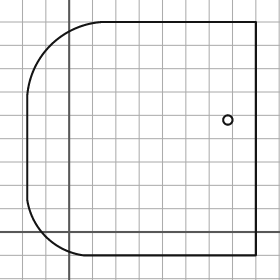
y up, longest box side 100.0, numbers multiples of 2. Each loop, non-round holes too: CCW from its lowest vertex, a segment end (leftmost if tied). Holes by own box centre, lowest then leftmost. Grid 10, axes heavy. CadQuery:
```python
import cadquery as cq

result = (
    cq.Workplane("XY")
    .moveTo(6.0, -10.0)
    .lineTo(80.0, -10.0)
    .lineTo(80.0, 90.0)
    .lineTo(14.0, 90.0)
    .threePointArc((-8.0, 80.0), (-18.0, 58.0))
    .lineTo(-18.0, 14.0)
    .threePointArc((-10.0, -2.0), (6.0, -10.0))
    .close()
    .moveTo(68.0, 48.0)
    .circle(2.0)
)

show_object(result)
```